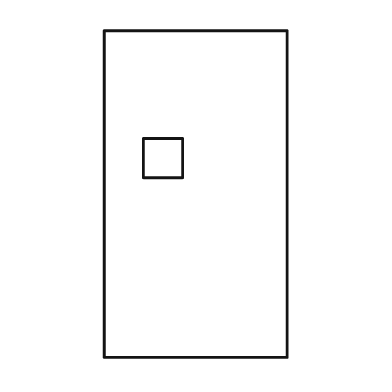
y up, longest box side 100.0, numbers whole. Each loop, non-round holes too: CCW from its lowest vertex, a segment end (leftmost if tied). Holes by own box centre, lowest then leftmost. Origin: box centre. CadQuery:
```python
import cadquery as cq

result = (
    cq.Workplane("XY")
    .moveTo(-28.0, -50.0)
    .lineTo(28.0, -50.0)
    .lineTo(28.0, 50.0)
    .lineTo(-28.0, 50.0)
    .close()
    .moveTo(-16.0, 5.0)
    .lineTo(-4.0, 5.0)
    .lineTo(-4.0, 17.0)
    .lineTo(-16.0, 17.0)
    .close()
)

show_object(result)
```